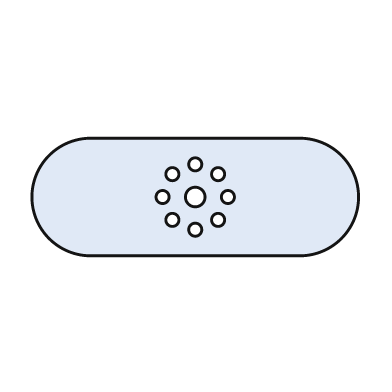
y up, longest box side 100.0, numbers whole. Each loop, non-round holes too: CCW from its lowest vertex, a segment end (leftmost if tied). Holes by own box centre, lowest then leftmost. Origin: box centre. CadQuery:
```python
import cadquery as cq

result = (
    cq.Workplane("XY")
    .moveTo(-32.0, -18.0)
    .lineTo(32.0, -18.0)
    .threePointArc((50.0, 0.0), (32.0, 18.0))
    .lineTo(-32.0, 18.0)
    .threePointArc((-50.0, 0.0), (-32.0, -18.0))
    .close()
    .moveTo(0.0, -10.0)
    .circle(2.0)
    .moveTo(-7.0, -7.0)
    .circle(2.0)
    .moveTo(7.0, -7.0)
    .circle(2.0)
    .moveTo(-10.0, 0.0)
    .circle(2.0)
    .moveTo(0.0, 0.0)
    .circle(3.0)
    .moveTo(10.0, 0.0)
    .circle(2.0)
    .moveTo(-7.0, 7.0)
    .circle(2.0)
    .moveTo(7.0, 7.0)
    .circle(2.0)
    .moveTo(0.0, 10.0)
    .circle(2.0)
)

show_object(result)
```